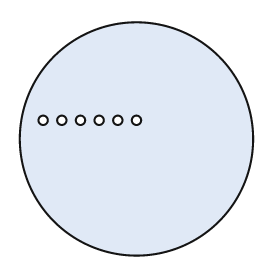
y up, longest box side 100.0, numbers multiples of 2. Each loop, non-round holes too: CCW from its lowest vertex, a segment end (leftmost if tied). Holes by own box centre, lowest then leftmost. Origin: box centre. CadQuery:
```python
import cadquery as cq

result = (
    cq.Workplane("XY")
    .moveTo(0.0, 0.0)
    .circle(50.0)
    .moveTo(-40.0, 8.0)
    .circle(2.0)
    .moveTo(-32.0, 8.0)
    .circle(2.0)
    .moveTo(-24.0, 8.0)
    .circle(2.0)
    .moveTo(-16.0, 8.0)
    .circle(2.0)
    .moveTo(-8.0, 8.0)
    .circle(2.0)
    .moveTo(0.0, 8.0)
    .circle(2.0)
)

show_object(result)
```